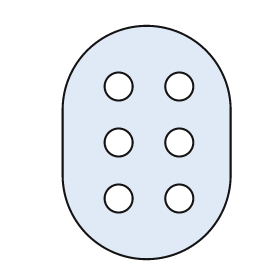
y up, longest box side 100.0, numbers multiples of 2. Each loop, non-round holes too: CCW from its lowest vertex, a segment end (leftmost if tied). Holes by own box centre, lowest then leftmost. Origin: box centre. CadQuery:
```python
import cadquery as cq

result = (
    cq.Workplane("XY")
    .moveTo(-36.0, -14.0)
    .threePointArc((0.0, -50.0), (36.0, -14.0))
    .lineTo(36.0, 14.0)
    .threePointArc((0.0, 50.0), (-36.0, 14.0))
    .close()
    .moveTo(-12.0, -24.0)
    .circle(6.0)
    .moveTo(14.0, -24.0)
    .circle(6.0)
    .moveTo(-12.0, 0.0)
    .circle(6.0)
    .moveTo(14.0, 0.0)
    .circle(6.0)
    .moveTo(-12.0, 24.0)
    .circle(6.0)
    .moveTo(14.0, 24.0)
    .circle(6.0)
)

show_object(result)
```